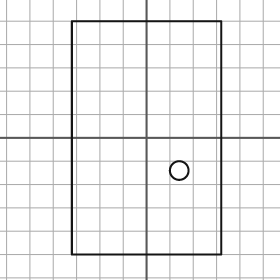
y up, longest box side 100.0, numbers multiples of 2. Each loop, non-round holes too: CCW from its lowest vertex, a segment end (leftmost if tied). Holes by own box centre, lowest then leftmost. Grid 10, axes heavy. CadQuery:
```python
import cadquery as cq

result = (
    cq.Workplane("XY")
    .moveTo(-32.0, -50.0)
    .lineTo(32.0, -50.0)
    .lineTo(32.0, 50.0)
    .lineTo(-32.0, 50.0)
    .close()
    .moveTo(14.0, -14.0)
    .circle(4.0)
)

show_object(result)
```